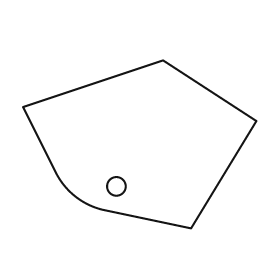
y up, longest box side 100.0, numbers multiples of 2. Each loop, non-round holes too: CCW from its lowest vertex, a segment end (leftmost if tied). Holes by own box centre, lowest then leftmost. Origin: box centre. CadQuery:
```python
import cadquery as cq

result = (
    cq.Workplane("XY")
    .moveTo(22.0, -36.0)
    .lineTo(50.0, 10.0)
    .lineTo(10.0, 36.0)
    .lineTo(-50.0, 16.0)
    .lineTo(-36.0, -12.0)
    .threePointArc((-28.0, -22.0), (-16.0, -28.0))
    .close()
    .moveTo(-10.0, -18.0)
    .circle(4.0)
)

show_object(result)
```